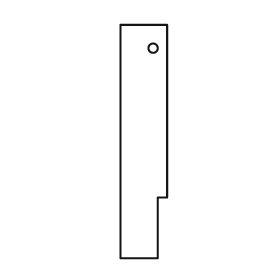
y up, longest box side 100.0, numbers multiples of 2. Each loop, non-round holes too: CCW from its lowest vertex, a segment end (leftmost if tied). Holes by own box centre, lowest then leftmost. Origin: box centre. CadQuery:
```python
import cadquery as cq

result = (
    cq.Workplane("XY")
    .moveTo(-10.0, -50.0)
    .lineTo(6.0, -50.0)
    .lineTo(6.0, -24.0)
    .lineTo(10.0, -24.0)
    .lineTo(10.0, 50.0)
    .lineTo(-10.0, 50.0)
    .close()
    .moveTo(4.0, 40.0)
    .circle(2.0)
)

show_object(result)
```